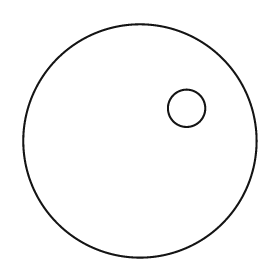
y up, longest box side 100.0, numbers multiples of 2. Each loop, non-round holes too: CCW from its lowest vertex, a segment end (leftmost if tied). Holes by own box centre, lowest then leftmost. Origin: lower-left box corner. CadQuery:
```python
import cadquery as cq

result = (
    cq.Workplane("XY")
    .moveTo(50.0, 50.0)
    .circle(50.0)
    .moveTo(70.0, 64.0)
    .circle(8.0)
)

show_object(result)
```